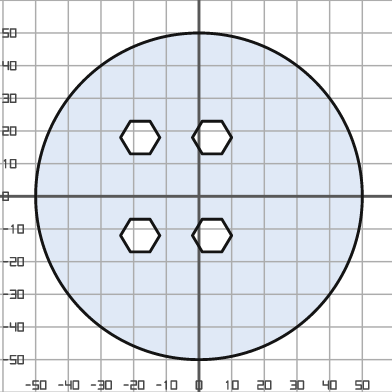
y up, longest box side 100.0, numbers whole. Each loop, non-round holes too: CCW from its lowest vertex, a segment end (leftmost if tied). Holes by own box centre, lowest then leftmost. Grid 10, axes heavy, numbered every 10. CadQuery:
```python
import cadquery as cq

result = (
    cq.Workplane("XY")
    .moveTo(0.0, 0.0)
    .circle(50.0)
    .moveTo(-21.0, -17.0)
    .lineTo(-15.0, -17.0)
    .lineTo(-12.0, -12.0)
    .lineTo(-15.0, -7.0)
    .lineTo(-21.0, -7.0)
    .lineTo(-24.0, -12.0)
    .close()
    .moveTo(1.0, -17.0)
    .lineTo(7.0, -17.0)
    .lineTo(10.0, -12.0)
    .lineTo(7.0, -7.0)
    .lineTo(1.0, -7.0)
    .lineTo(-2.0, -12.0)
    .close()
    .moveTo(-21.0, 13.0)
    .lineTo(-15.0, 13.0)
    .lineTo(-12.0, 18.0)
    .lineTo(-15.0, 23.0)
    .lineTo(-21.0, 23.0)
    .lineTo(-24.0, 18.0)
    .close()
    .moveTo(1.0, 13.0)
    .lineTo(7.0, 13.0)
    .lineTo(10.0, 18.0)
    .lineTo(7.0, 23.0)
    .lineTo(1.0, 23.0)
    .lineTo(-2.0, 18.0)
    .close()
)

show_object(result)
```